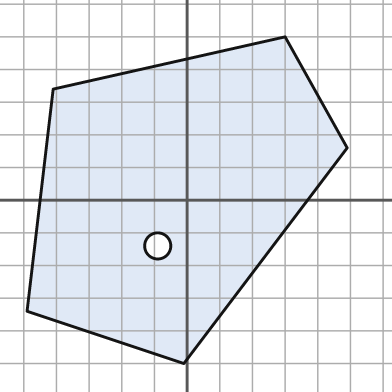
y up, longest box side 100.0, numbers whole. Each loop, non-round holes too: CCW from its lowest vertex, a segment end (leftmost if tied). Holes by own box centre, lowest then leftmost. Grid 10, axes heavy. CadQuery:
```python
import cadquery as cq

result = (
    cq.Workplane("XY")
    .moveTo(-1.0, -50.0)
    .lineTo(49.0, 16.0)
    .lineTo(30.0, 50.0)
    .lineTo(-41.0, 34.0)
    .lineTo(-49.0, -34.0)
    .close()
    .moveTo(-9.0, -14.0)
    .circle(4.0)
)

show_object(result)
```